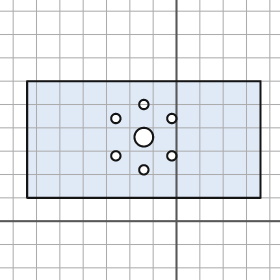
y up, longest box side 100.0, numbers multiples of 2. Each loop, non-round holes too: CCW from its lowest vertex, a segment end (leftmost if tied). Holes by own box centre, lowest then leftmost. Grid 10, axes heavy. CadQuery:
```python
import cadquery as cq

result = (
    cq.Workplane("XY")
    .moveTo(-64.0, 10.0)
    .lineTo(36.0, 10.0)
    .lineTo(36.0, 60.0)
    .lineTo(-64.0, 60.0)
    .close()
    .moveTo(-14.0, 22.0)
    .circle(2.0)
    .moveTo(-26.0, 28.0)
    .circle(2.0)
    .moveTo(-2.0, 28.0)
    .circle(2.0)
    .moveTo(-14.0, 36.0)
    .circle(4.0)
    .moveTo(-26.0, 44.0)
    .circle(2.0)
    .moveTo(-2.0, 44.0)
    .circle(2.0)
    .moveTo(-14.0, 50.0)
    .circle(2.0)
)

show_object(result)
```